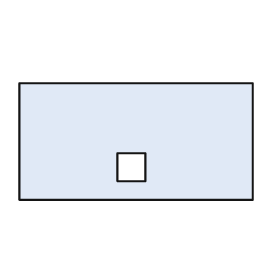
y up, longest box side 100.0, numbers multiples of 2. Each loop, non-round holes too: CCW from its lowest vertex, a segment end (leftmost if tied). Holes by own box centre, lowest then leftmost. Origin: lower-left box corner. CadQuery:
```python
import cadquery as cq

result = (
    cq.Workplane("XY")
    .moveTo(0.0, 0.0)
    .lineTo(100.0, 0.0)
    .lineTo(100.0, 50.0)
    .lineTo(0.0, 50.0)
    .close()
    .moveTo(42.0, 8.0)
    .lineTo(54.0, 8.0)
    .lineTo(54.0, 20.0)
    .lineTo(42.0, 20.0)
    .close()
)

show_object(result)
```